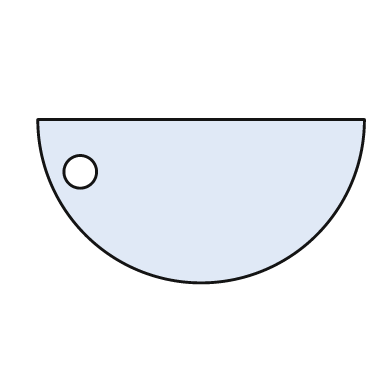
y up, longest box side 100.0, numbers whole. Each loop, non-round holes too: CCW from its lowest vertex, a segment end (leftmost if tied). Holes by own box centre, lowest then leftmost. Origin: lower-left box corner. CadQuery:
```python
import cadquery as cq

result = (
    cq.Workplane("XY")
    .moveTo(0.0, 50.0)
    .threePointArc((50.0, 0.0), (100.0, 50.0))
    .close()
    .moveTo(13.0, 34.0)
    .circle(5.0)
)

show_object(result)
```